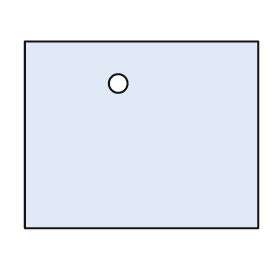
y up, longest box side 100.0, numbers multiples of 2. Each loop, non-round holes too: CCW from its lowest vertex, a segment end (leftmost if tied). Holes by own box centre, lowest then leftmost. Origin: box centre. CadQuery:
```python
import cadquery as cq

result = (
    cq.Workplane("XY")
    .moveTo(-50.0, -40.0)
    .lineTo(50.0, -40.0)
    .lineTo(50.0, 40.0)
    .lineTo(-50.0, 40.0)
    .close()
    .moveTo(-10.0, 22.0)
    .circle(4.0)
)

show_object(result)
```